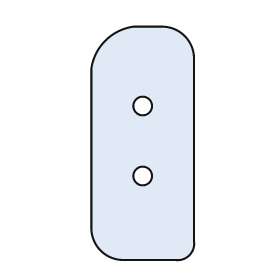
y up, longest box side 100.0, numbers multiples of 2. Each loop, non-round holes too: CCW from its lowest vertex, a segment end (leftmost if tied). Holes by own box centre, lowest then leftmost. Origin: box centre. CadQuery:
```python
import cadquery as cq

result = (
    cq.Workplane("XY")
    .moveTo(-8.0, -50.0)
    .lineTo(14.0, -50.0)
    .threePointArc((20.0, -48.0), (22.0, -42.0))
    .lineTo(22.0, 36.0)
    .threePointArc((18.0, 46.0), (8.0, 50.0))
    .lineTo(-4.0, 50.0)
    .threePointArc((-16.0, 44.0), (-22.0, 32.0))
    .lineTo(-22.0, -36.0)
    .threePointArc((-18.0, -46.0), (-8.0, -50.0))
    .close()
    .moveTo(0.0, -14.0)
    .circle(4.0)
    .moveTo(0.0, 16.0)
    .circle(4.0)
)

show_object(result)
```